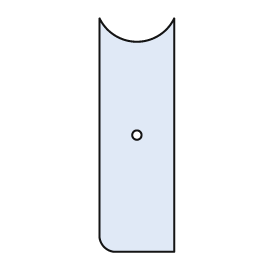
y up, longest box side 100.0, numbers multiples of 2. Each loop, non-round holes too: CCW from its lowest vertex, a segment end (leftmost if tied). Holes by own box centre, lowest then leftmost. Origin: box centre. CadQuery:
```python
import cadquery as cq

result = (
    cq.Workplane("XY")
    .moveTo(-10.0, -50.0)
    .lineTo(16.0, -50.0)
    .lineTo(16.0, 50.0)
    .threePointArc((0.0, 40.0), (-16.0, 50.0))
    .lineTo(-16.0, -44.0)
    .threePointArc((-14.0, -48.0), (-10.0, -50.0))
    .close()
    .moveTo(0.0, 0.0)
    .circle(2.0)
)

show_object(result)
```